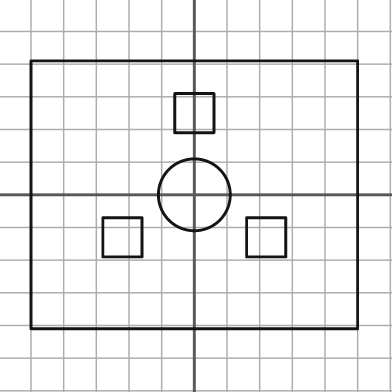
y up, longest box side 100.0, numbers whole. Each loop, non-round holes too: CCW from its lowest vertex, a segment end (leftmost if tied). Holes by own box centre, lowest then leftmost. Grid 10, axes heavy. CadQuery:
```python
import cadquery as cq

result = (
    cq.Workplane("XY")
    .moveTo(-50.0, -41.0)
    .lineTo(50.0, -41.0)
    .lineTo(50.0, 41.0)
    .lineTo(-50.0, 41.0)
    .close()
    .moveTo(-28.0, -19.0)
    .lineTo(-16.0, -19.0)
    .lineTo(-16.0, -7.0)
    .lineTo(-28.0, -7.0)
    .close()
    .moveTo(16.0, -19.0)
    .lineTo(28.0, -19.0)
    .lineTo(28.0, -7.0)
    .lineTo(16.0, -7.0)
    .close()
    .moveTo(0.0, 0.0)
    .circle(11.0)
    .moveTo(-6.0, 19.0)
    .lineTo(6.0, 19.0)
    .lineTo(6.0, 31.0)
    .lineTo(-6.0, 31.0)
    .close()
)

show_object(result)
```